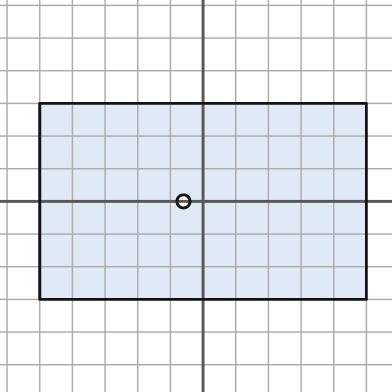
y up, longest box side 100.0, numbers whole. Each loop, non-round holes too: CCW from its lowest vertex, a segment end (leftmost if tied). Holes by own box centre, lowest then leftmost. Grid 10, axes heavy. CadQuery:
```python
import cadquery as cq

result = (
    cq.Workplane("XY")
    .moveTo(-50.0, -30.0)
    .lineTo(50.0, -30.0)
    .lineTo(50.0, 30.0)
    .lineTo(-50.0, 30.0)
    .close()
    .moveTo(-6.0, 0.0)
    .circle(2.0)
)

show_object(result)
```